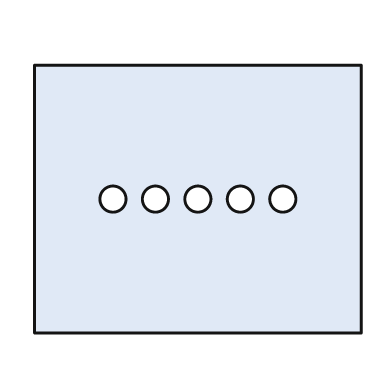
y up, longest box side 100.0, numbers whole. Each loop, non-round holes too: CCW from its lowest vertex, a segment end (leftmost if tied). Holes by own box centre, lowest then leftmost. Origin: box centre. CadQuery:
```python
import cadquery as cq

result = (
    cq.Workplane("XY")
    .moveTo(-50.0, -41.0)
    .lineTo(50.0, -41.0)
    .lineTo(50.0, 41.0)
    .lineTo(-50.0, 41.0)
    .close()
    .moveTo(-26.0, 0.0)
    .circle(4.0)
    .moveTo(-13.0, 0.0)
    .circle(4.0)
    .moveTo(0.0, 0.0)
    .circle(4.0)
    .moveTo(13.0, 0.0)
    .circle(4.0)
    .moveTo(26.0, 0.0)
    .circle(4.0)
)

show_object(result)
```